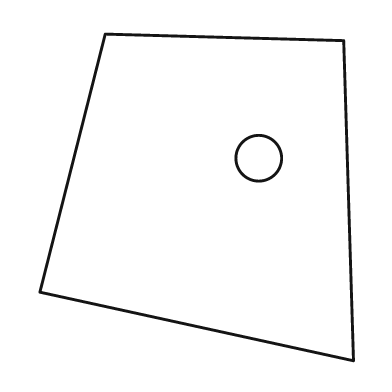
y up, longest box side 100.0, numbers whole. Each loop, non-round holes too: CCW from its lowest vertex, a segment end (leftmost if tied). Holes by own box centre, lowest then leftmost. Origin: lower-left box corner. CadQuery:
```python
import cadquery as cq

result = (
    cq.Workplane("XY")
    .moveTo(96.0, 0.0)
    .lineTo(93.0, 98.0)
    .lineTo(20.0, 100.0)
    .lineTo(0.0, 21.0)
    .close()
    .moveTo(67.0, 62.0)
    .circle(7.0)
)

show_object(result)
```